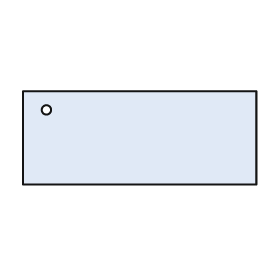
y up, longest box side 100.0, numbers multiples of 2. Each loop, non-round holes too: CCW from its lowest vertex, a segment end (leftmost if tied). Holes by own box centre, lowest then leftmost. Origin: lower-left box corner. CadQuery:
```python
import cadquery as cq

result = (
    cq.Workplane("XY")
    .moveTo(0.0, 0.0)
    .lineTo(100.0, 0.0)
    .lineTo(100.0, 40.0)
    .lineTo(0.0, 40.0)
    .close()
    .moveTo(10.0, 32.0)
    .circle(2.0)
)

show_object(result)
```